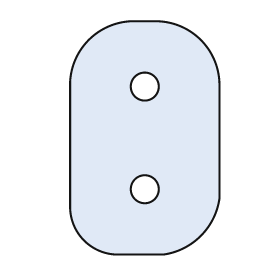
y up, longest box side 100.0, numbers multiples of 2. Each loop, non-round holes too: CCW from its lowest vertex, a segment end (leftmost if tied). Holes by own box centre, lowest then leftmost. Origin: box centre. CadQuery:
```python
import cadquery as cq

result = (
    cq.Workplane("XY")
    .moveTo(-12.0, -50.0)
    .lineTo(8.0, -50.0)
    .threePointArc((24.0, -42.0), (32.0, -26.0))
    .lineTo(32.0, 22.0)
    .threePointArc((24.0, 42.0), (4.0, 50.0))
    .lineTo(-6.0, 50.0)
    .threePointArc((-24.0, 42.0), (-32.0, 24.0))
    .lineTo(-32.0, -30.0)
    .threePointArc((-26.0, -44.0), (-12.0, -50.0))
    .close()
    .moveTo(0.0, -22.0)
    .circle(6.0)
    .moveTo(0.0, 22.0)
    .circle(6.0)
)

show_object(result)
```